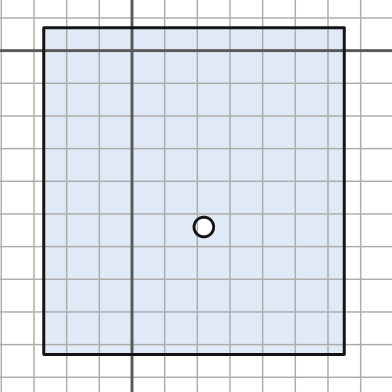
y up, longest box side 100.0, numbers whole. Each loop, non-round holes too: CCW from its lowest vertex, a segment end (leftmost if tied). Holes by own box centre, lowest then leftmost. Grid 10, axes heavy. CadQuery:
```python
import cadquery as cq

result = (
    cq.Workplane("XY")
    .moveTo(-27.0, -93.0)
    .lineTo(65.0, -93.0)
    .lineTo(65.0, 7.0)
    .lineTo(-27.0, 7.0)
    .close()
    .moveTo(22.0, -54.0)
    .circle(3.0)
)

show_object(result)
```